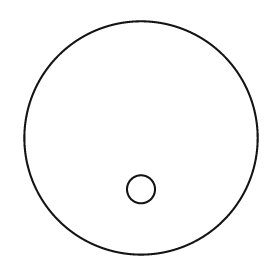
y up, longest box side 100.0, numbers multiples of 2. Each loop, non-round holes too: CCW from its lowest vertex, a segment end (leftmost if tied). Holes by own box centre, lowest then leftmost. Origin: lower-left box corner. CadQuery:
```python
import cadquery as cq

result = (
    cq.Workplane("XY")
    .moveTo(50.0, 50.0)
    .circle(50.0)
    .moveTo(50.0, 28.0)
    .circle(6.0)
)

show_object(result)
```